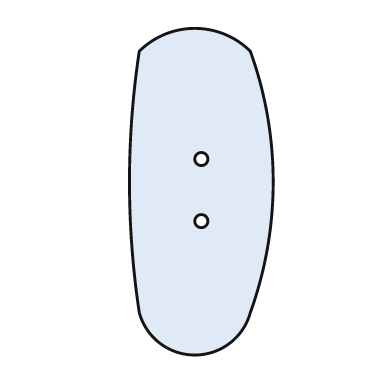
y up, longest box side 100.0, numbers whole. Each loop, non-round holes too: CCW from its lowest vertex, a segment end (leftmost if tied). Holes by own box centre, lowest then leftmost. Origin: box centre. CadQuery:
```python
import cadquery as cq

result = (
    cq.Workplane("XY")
    .moveTo(-19.0, -37.0)
    .threePointArc((-2.0, -50.0), (15.0, -37.0))
    .threePointArc((22.0, 3.0), (15.0, 43.0))
    .threePointArc((-2.0, 50.0), (-19.0, 43.0))
    .threePointArc((-22.0, 3.0), (-19.0, -37.0))
    .close()
    .moveTo(0.0, -9.0)
    .circle(2.0)
    .moveTo(0.0, 10.0)
    .circle(2.0)
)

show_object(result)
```